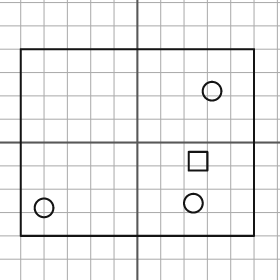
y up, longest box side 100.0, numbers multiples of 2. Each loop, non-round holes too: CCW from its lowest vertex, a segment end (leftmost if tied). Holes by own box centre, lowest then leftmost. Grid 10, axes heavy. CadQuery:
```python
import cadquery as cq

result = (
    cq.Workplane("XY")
    .moveTo(-50.0, -40.0)
    .lineTo(50.0, -40.0)
    .lineTo(50.0, 40.0)
    .lineTo(-50.0, 40.0)
    .close()
    .moveTo(-40.0, -28.0)
    .circle(4.0)
    .moveTo(24.0, -26.0)
    .circle(4.0)
    .moveTo(22.0, -12.0)
    .lineTo(30.0, -12.0)
    .lineTo(30.0, -4.0)
    .lineTo(22.0, -4.0)
    .close()
    .moveTo(32.0, 22.0)
    .circle(4.0)
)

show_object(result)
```